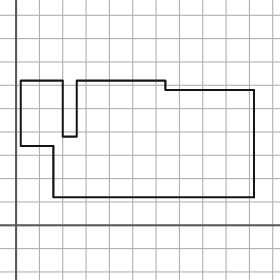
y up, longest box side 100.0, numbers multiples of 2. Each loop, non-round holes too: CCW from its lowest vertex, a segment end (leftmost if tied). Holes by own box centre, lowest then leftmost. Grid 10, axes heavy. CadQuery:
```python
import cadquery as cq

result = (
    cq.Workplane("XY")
    .moveTo(16.0, 12.0)
    .lineTo(102.0, 12.0)
    .lineTo(102.0, 58.0)
    .lineTo(64.0, 58.0)
    .lineTo(64.0, 62.0)
    .lineTo(26.0, 62.0)
    .lineTo(26.0, 38.0)
    .lineTo(20.0, 38.0)
    .lineTo(20.0, 62.0)
    .lineTo(2.0, 62.0)
    .lineTo(2.0, 34.0)
    .lineTo(16.0, 34.0)
    .close()
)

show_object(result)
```